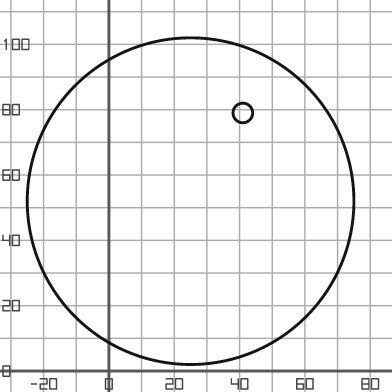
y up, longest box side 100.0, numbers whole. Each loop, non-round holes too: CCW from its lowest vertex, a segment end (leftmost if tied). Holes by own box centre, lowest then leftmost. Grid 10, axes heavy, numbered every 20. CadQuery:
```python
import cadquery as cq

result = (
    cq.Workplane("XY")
    .moveTo(25.0, 52.0)
    .circle(50.0)
    .moveTo(41.0, 79.0)
    .circle(3.0)
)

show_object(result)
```